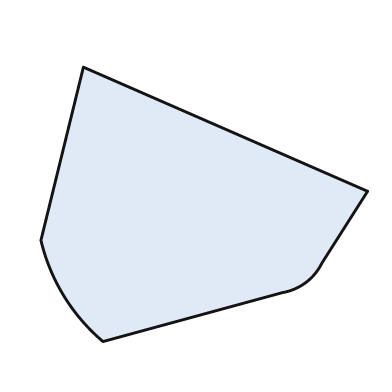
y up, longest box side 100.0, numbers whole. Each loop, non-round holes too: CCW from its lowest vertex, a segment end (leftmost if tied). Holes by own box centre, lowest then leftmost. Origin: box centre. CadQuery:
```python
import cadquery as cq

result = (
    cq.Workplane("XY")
    .moveTo(-31.0, -42.0)
    .lineTo(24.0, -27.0)
    .threePointArc((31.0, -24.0), (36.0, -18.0))
    .lineTo(50.0, 4.0)
    .lineTo(-37.0, 42.0)
    .lineTo(-50.0, -11.0)
    .threePointArc((-43.0, -28.0), (-31.0, -42.0))
    .close()
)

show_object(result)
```